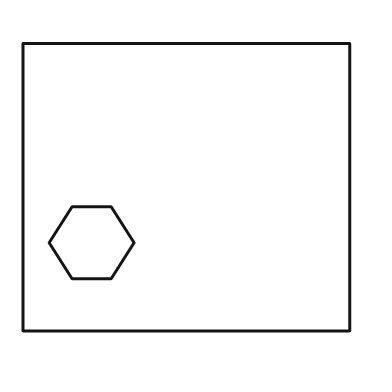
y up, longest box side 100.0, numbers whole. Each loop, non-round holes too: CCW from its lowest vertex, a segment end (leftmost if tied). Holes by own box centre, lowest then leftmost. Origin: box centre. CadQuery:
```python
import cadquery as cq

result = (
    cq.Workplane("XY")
    .moveTo(-50.0, -44.0)
    .lineTo(50.0, -44.0)
    .lineTo(50.0, 44.0)
    .lineTo(-50.0, 44.0)
    .close()
    .moveTo(-35.0, -28.0)
    .lineTo(-23.0, -28.0)
    .lineTo(-16.0, -17.0)
    .lineTo(-23.0, -6.0)
    .lineTo(-35.0, -6.0)
    .lineTo(-42.0, -17.0)
    .close()
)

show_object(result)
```